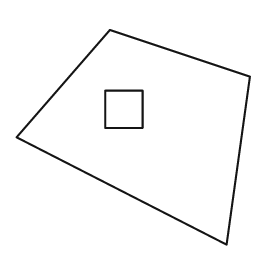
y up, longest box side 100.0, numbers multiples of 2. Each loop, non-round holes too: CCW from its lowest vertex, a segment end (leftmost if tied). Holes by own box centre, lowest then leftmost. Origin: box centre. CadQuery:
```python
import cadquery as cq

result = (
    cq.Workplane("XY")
    .moveTo(40.0, -46.0)
    .lineTo(50.0, 26.0)
    .lineTo(-10.0, 46.0)
    .lineTo(-50.0, 0.0)
    .close()
    .moveTo(-12.0, 4.0)
    .lineTo(4.0, 4.0)
    .lineTo(4.0, 20.0)
    .lineTo(-12.0, 20.0)
    .close()
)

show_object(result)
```